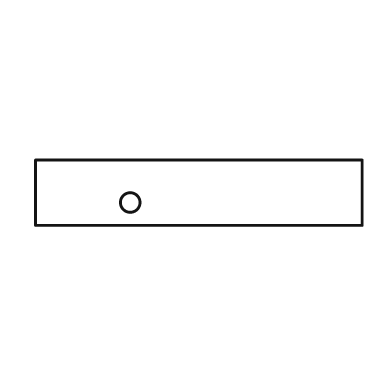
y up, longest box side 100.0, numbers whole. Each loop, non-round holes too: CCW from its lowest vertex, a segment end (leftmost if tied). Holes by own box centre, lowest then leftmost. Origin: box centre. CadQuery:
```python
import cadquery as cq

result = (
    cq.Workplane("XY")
    .moveTo(-50.0, -10.0)
    .lineTo(50.0, -10.0)
    .lineTo(50.0, 10.0)
    .lineTo(-50.0, 10.0)
    .close()
    .moveTo(-21.0, -3.0)
    .circle(3.0)
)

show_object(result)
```